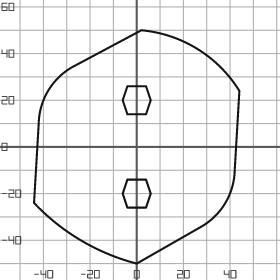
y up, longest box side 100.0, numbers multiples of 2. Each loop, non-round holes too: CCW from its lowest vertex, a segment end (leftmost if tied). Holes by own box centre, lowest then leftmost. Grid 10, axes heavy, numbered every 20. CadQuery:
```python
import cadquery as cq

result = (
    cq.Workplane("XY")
    .moveTo(0.0, -50.0)
    .lineTo(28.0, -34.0)
    .threePointArc((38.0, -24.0), (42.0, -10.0))
    .lineTo(44.0, 24.0)
    .threePointArc((26.0, 42.0), (2.0, 50.0))
    .lineTo(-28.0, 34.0)
    .threePointArc((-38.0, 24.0), (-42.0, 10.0))
    .lineTo(-44.0, -24.0)
    .threePointArc((-24.0, -40.0), (0.0, -50.0))
    .close()
    .moveTo(-4.0, -26.0)
    .lineTo(4.0, -26.0)
    .lineTo(6.0, -20.0)
    .lineTo(4.0, -14.0)
    .lineTo(-4.0, -14.0)
    .lineTo(-6.0, -20.0)
    .close()
    .moveTo(-4.0, 14.0)
    .lineTo(4.0, 14.0)
    .lineTo(6.0, 20.0)
    .lineTo(4.0, 26.0)
    .lineTo(-4.0, 26.0)
    .lineTo(-6.0, 20.0)
    .close()
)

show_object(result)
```